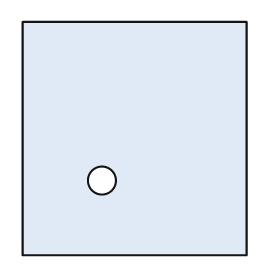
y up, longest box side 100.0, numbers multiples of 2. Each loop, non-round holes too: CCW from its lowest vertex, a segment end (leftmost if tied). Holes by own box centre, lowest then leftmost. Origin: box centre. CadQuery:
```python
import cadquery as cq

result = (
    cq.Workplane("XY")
    .moveTo(-48.0, -50.0)
    .lineTo(48.0, -50.0)
    .lineTo(48.0, 50.0)
    .lineTo(-48.0, 50.0)
    .close()
    .moveTo(-14.0, -18.0)
    .circle(6.0)
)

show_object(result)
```